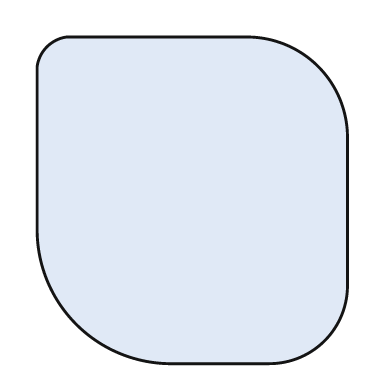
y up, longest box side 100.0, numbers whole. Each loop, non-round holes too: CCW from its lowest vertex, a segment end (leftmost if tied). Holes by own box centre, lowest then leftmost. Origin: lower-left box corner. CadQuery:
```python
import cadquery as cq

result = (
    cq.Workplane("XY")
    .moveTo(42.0, 0.0)
    .lineTo(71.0, 0.0)
    .threePointArc((88.0, 7.0), (95.0, 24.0))
    .lineTo(95.0, 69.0)
    .threePointArc((86.0, 91.0), (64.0, 100.0))
    .lineTo(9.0, 100.0)
    .threePointArc((3.0, 97.0), (0.0, 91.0))
    .lineTo(0.0, 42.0)
    .threePointArc((12.0, 12.0), (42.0, 0.0))
    .close()
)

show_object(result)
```